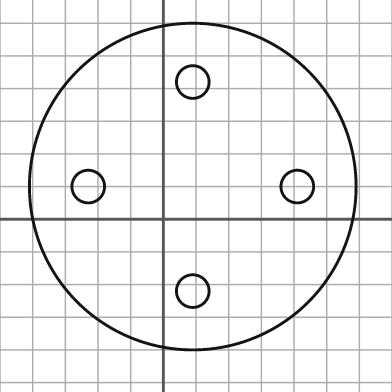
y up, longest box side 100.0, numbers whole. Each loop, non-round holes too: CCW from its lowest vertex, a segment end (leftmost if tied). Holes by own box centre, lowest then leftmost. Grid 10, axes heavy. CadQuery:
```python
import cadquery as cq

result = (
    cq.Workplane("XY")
    .moveTo(9.0, 10.0)
    .circle(50.0)
    .moveTo(9.0, -22.0)
    .circle(5.0)
    .moveTo(-23.0, 10.0)
    .circle(5.0)
    .moveTo(41.0, 10.0)
    .circle(5.0)
    .moveTo(9.0, 42.0)
    .circle(5.0)
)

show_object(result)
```